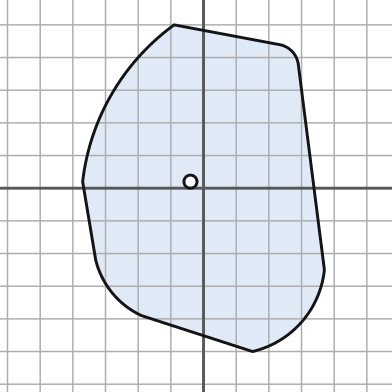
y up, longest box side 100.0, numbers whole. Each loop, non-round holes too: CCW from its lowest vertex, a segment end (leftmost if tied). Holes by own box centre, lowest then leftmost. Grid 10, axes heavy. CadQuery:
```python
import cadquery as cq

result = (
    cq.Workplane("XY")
    .moveTo(15.0, -50.0)
    .threePointArc((30.0, -41.0), (37.0, -25.0))
    .lineTo(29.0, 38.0)
    .threePointArc((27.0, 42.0), (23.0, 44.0))
    .lineTo(-9.0, 50.0)
    .threePointArc((-28.0, 29.0), (-37.0, 2.0))
    .lineTo(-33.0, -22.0)
    .threePointArc((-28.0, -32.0), (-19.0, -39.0))
    .close()
    .moveTo(-4.0, 2.0)
    .circle(2.0)
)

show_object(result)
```